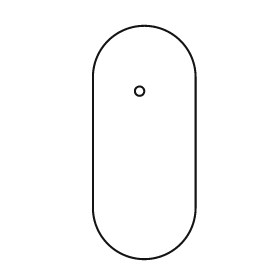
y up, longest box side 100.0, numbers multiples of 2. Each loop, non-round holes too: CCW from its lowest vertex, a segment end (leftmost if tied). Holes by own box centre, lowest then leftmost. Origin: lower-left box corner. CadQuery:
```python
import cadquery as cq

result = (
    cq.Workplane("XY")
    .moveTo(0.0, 22.0)
    .threePointArc((22.0, 0.0), (44.0, 22.0))
    .lineTo(44.0, 78.0)
    .threePointArc((22.0, 100.0), (0.0, 78.0))
    .close()
    .moveTo(20.0, 72.0)
    .circle(2.0)
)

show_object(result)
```